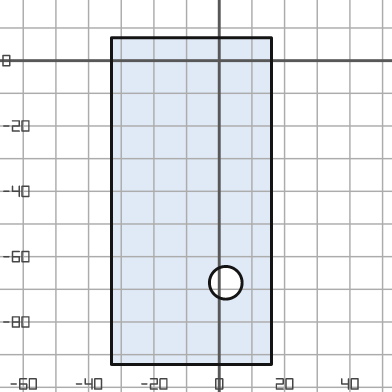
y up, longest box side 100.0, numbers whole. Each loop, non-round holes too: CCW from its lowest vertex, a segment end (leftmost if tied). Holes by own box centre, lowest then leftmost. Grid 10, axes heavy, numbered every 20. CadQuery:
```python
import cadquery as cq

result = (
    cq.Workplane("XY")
    .moveTo(-33.0, -93.0)
    .lineTo(16.0, -93.0)
    .lineTo(16.0, 7.0)
    .lineTo(-33.0, 7.0)
    .close()
    .moveTo(2.0, -68.0)
    .circle(5.0)
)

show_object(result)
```